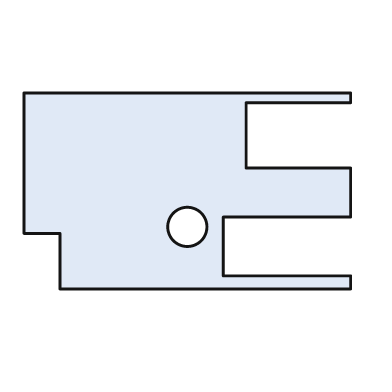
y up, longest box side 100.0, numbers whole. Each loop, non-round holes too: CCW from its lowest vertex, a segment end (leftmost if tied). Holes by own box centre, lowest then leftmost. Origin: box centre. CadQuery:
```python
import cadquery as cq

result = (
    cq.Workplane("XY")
    .moveTo(-39.0, -30.0)
    .lineTo(50.0, -30.0)
    .lineTo(50.0, -26.0)
    .lineTo(11.0, -26.0)
    .lineTo(11.0, -8.0)
    .lineTo(50.0, -8.0)
    .lineTo(50.0, 7.0)
    .lineTo(18.0, 7.0)
    .lineTo(18.0, 27.0)
    .lineTo(50.0, 27.0)
    .lineTo(50.0, 30.0)
    .lineTo(-50.0, 30.0)
    .lineTo(-50.0, -13.0)
    .lineTo(-39.0, -13.0)
    .close()
    .moveTo(0.0, -11.0)
    .circle(6.0)
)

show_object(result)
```